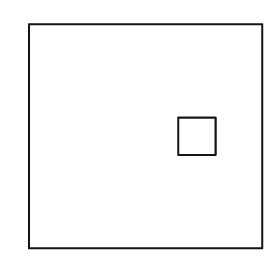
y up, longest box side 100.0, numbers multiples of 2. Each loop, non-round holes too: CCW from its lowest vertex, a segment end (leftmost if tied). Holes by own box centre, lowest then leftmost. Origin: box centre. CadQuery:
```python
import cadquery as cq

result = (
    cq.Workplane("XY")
    .moveTo(-50.0, -48.0)
    .lineTo(50.0, -48.0)
    .lineTo(50.0, 48.0)
    .lineTo(-50.0, 48.0)
    .close()
    .moveTo(14.0, -8.0)
    .lineTo(30.0, -8.0)
    .lineTo(30.0, 8.0)
    .lineTo(14.0, 8.0)
    .close()
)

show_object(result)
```